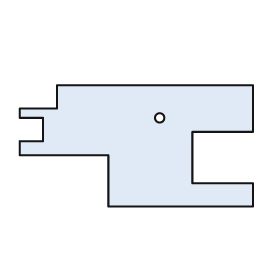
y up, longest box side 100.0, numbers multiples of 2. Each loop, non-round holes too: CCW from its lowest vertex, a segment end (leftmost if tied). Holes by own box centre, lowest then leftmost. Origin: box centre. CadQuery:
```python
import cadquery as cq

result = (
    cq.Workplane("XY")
    .moveTo(-12.0, -26.0)
    .lineTo(50.0, -26.0)
    .lineTo(50.0, -16.0)
    .lineTo(24.0, -16.0)
    .lineTo(24.0, 6.0)
    .lineTo(50.0, 6.0)
    .lineTo(50.0, 26.0)
    .lineTo(-34.0, 26.0)
    .lineTo(-34.0, 16.0)
    .lineTo(-50.0, 16.0)
    .lineTo(-50.0, 12.0)
    .lineTo(-40.0, 12.0)
    .lineTo(-40.0, 2.0)
    .lineTo(-50.0, 2.0)
    .lineTo(-50.0, -4.0)
    .lineTo(-12.0, -4.0)
    .close()
    .moveTo(10.0, 12.0)
    .circle(2.0)
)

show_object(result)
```